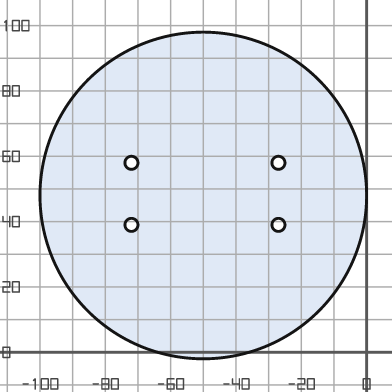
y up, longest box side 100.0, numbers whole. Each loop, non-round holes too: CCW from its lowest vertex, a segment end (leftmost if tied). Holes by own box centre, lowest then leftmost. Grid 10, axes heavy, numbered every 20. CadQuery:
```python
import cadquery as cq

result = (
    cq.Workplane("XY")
    .moveTo(-50.0, 48.0)
    .circle(50.0)
    .moveTo(-72.0, 39.0)
    .circle(2.0)
    .moveTo(-27.0, 39.0)
    .circle(2.0)
    .moveTo(-72.0, 58.0)
    .circle(2.0)
    .moveTo(-27.0, 58.0)
    .circle(2.0)
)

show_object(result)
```